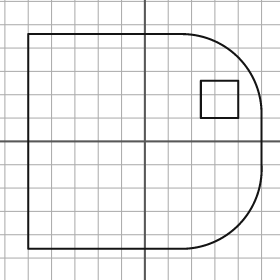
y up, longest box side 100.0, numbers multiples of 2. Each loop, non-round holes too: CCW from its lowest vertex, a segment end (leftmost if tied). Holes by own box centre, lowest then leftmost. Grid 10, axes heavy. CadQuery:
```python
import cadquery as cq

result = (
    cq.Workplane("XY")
    .moveTo(-50.0, -46.0)
    .lineTo(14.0, -46.0)
    .threePointArc((40.0, -36.0), (50.0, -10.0))
    .lineTo(50.0, 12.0)
    .threePointArc((40.0, 36.0), (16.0, 46.0))
    .lineTo(-50.0, 46.0)
    .close()
    .moveTo(24.0, 10.0)
    .lineTo(40.0, 10.0)
    .lineTo(40.0, 26.0)
    .lineTo(24.0, 26.0)
    .close()
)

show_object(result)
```